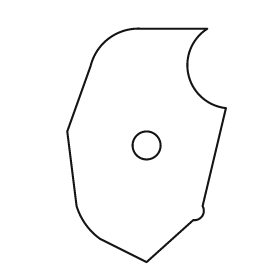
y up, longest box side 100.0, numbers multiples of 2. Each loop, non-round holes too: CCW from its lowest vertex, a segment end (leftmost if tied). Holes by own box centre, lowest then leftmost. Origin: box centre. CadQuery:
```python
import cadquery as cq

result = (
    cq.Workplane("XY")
    .moveTo(0.0, -50.0)
    .lineTo(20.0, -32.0)
    .threePointArc((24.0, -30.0), (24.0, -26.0))
    .lineTo(34.0, 16.0)
    .threePointArc((18.0, 30.0), (26.0, 50.0))
    .lineTo(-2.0, 50.0)
    .threePointArc((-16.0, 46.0), (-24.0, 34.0))
    .lineTo(-34.0, 6.0)
    .lineTo(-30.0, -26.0)
    .threePointArc((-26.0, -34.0), (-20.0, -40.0))
    .close()
    .moveTo(0.0, 0.0)
    .circle(6.0)
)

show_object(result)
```